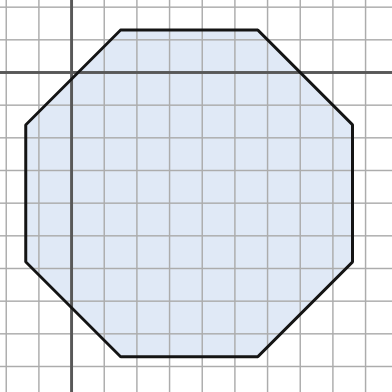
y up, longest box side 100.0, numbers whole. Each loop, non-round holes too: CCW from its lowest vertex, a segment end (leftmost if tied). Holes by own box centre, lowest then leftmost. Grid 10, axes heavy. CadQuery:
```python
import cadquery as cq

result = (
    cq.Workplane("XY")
    .moveTo(15.0, -87.0)
    .lineTo(57.0, -87.0)
    .lineTo(86.0, -58.0)
    .lineTo(86.0, -16.0)
    .lineTo(57.0, 13.0)
    .lineTo(15.0, 13.0)
    .lineTo(-14.0, -16.0)
    .lineTo(-14.0, -58.0)
    .close()
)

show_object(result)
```